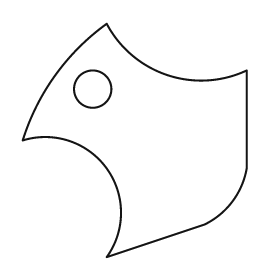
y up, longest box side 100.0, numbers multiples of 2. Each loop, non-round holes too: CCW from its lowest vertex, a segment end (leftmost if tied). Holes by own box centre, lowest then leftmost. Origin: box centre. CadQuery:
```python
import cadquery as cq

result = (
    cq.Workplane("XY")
    .moveTo(-12.0, -50.0)
    .lineTo(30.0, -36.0)
    .threePointArc((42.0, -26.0), (48.0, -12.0))
    .lineTo(48.0, 30.0)
    .threePointArc((14.0, 28.0), (-12.0, 50.0))
    .threePointArc((-34.0, 28.0), (-48.0, 0.0))
    .threePointArc((-12.0, -12.0), (-12.0, -50.0))
    .close()
    .moveTo(-18.0, 22.0)
    .circle(8.0)
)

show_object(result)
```